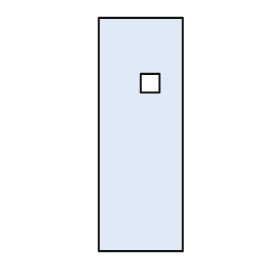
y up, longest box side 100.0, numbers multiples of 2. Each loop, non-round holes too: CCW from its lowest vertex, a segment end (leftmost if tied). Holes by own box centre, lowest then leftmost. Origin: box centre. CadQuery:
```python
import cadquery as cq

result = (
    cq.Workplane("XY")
    .moveTo(-18.0, -50.0)
    .lineTo(18.0, -50.0)
    .lineTo(18.0, 50.0)
    .lineTo(-18.0, 50.0)
    .close()
    .moveTo(0.0, 18.0)
    .lineTo(8.0, 18.0)
    .lineTo(8.0, 26.0)
    .lineTo(0.0, 26.0)
    .close()
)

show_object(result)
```